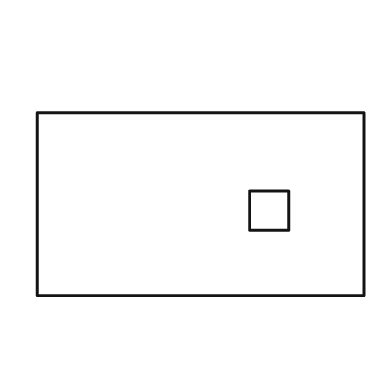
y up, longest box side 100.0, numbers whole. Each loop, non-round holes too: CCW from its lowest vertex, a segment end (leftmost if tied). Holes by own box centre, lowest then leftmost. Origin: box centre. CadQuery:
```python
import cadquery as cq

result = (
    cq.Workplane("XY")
    .moveTo(-50.0, -28.0)
    .lineTo(50.0, -28.0)
    .lineTo(50.0, 28.0)
    .lineTo(-50.0, 28.0)
    .close()
    .moveTo(15.0, -8.0)
    .lineTo(27.0, -8.0)
    .lineTo(27.0, 4.0)
    .lineTo(15.0, 4.0)
    .close()
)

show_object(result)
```